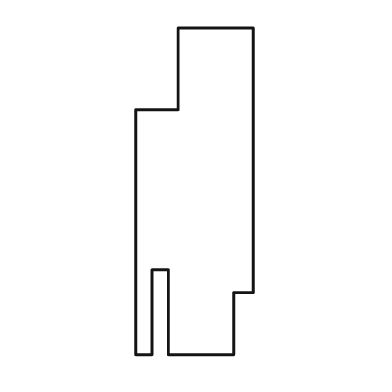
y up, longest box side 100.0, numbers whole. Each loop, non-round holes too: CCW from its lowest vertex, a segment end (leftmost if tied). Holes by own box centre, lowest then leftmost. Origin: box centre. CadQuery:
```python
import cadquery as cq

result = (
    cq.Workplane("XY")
    .moveTo(-18.0, -50.0)
    .lineTo(-13.0, -50.0)
    .lineTo(-13.0, -24.0)
    .lineTo(-8.0, -24.0)
    .lineTo(-8.0, -50.0)
    .lineTo(12.0, -50.0)
    .lineTo(12.0, -31.0)
    .lineTo(18.0, -31.0)
    .lineTo(18.0, 50.0)
    .lineTo(-5.0, 50.0)
    .lineTo(-5.0, 25.0)
    .lineTo(-18.0, 25.0)
    .close()
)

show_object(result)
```